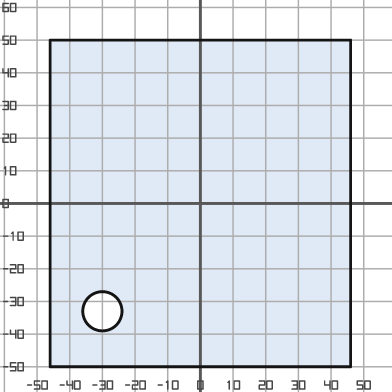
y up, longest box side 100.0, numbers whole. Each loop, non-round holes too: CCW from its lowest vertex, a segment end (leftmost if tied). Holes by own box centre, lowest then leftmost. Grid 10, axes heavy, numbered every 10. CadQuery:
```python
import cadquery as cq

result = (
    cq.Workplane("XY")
    .moveTo(-46.0, -50.0)
    .lineTo(46.0, -50.0)
    .lineTo(46.0, 50.0)
    .lineTo(-46.0, 50.0)
    .close()
    .moveTo(-30.0, -33.0)
    .circle(6.0)
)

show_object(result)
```